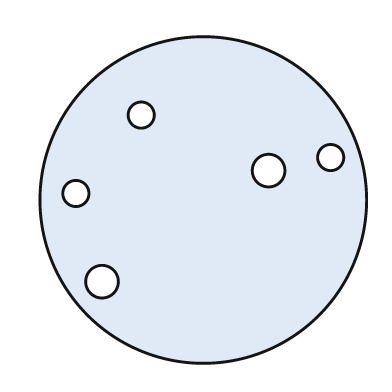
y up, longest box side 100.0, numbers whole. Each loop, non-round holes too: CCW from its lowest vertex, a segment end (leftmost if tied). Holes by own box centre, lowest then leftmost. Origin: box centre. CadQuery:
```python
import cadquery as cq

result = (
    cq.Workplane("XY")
    .moveTo(0.0, 0.0)
    .circle(50.0)
    .moveTo(-31.0, -25.0)
    .circle(5.0)
    .moveTo(-39.0, 2.0)
    .circle(4.0)
    .moveTo(20.0, 9.0)
    .circle(5.0)
    .moveTo(39.0, 13.0)
    .circle(4.0)
    .moveTo(-19.0, 26.0)
    .circle(4.0)
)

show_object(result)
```